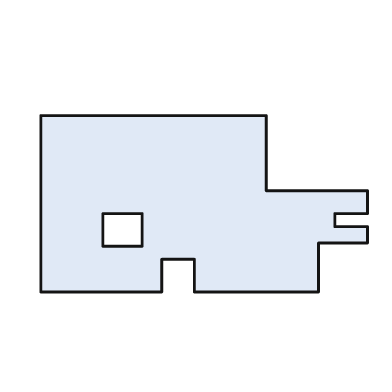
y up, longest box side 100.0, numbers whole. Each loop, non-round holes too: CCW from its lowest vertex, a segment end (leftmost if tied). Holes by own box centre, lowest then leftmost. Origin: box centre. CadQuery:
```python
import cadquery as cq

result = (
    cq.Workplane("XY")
    .moveTo(-50.0, -27.0)
    .lineTo(-13.0, -27.0)
    .lineTo(-13.0, -17.0)
    .lineTo(-3.0, -17.0)
    .lineTo(-3.0, -27.0)
    .lineTo(35.0, -27.0)
    .lineTo(35.0, -12.0)
    .lineTo(50.0, -12.0)
    .lineTo(50.0, -7.0)
    .lineTo(40.0, -7.0)
    .lineTo(40.0, -3.0)
    .lineTo(50.0, -3.0)
    .lineTo(50.0, 4.0)
    .lineTo(19.0, 4.0)
    .lineTo(19.0, 27.0)
    .lineTo(-50.0, 27.0)
    .close()
    .moveTo(-31.0, -13.0)
    .lineTo(-19.0, -13.0)
    .lineTo(-19.0, -3.0)
    .lineTo(-31.0, -3.0)
    .close()
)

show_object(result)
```